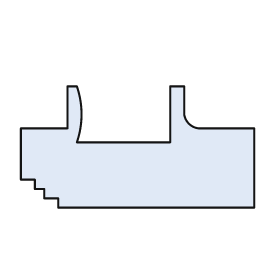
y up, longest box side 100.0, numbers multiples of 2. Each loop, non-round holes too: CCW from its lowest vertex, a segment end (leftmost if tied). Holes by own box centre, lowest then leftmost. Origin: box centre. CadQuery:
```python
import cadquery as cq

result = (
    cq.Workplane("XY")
    .moveTo(-34.0, -26.0)
    .lineTo(50.0, -26.0)
    .lineTo(50.0, 8.0)
    .lineTo(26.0, 8.0)
    .threePointArc((22.0, 10.0), (20.0, 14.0))
    .lineTo(20.0, 26.0)
    .lineTo(14.0, 26.0)
    .lineTo(14.0, 2.0)
    .lineTo(-26.0, 2.0)
    .threePointArc((-24.0, 14.0), (-26.0, 26.0))
    .lineTo(-30.0, 26.0)
    .lineTo(-30.0, 8.0)
    .lineTo(-50.0, 8.0)
    .lineTo(-50.0, -14.0)
    .lineTo(-44.0, -14.0)
    .lineTo(-44.0, -18.0)
    .lineTo(-40.0, -18.0)
    .lineTo(-40.0, -22.0)
    .lineTo(-34.0, -22.0)
    .close()
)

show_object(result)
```